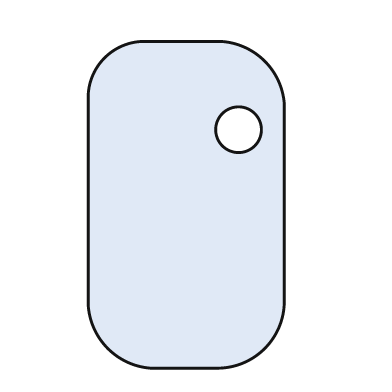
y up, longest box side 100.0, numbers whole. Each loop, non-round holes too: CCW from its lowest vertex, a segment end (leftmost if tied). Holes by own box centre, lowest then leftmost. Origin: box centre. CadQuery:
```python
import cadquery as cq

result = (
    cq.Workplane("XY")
    .moveTo(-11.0, -50.0)
    .lineTo(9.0, -50.0)
    .threePointArc((24.0, -44.0), (30.0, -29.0))
    .lineTo(30.0, 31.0)
    .threePointArc((24.0, 44.0), (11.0, 50.0))
    .lineTo(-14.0, 50.0)
    .threePointArc((-25.0, 45.0), (-30.0, 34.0))
    .lineTo(-30.0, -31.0)
    .threePointArc((-24.0, -44.0), (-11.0, -50.0))
    .close()
    .moveTo(16.0, 23.0)
    .circle(7.0)
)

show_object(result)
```